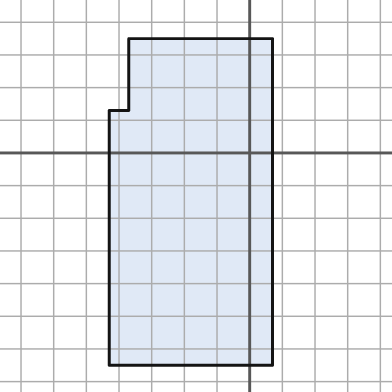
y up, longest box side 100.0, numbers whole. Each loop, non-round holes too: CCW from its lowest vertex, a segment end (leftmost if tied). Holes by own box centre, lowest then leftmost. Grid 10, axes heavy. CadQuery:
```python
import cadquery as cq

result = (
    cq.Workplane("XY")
    .moveTo(-43.0, -65.0)
    .lineTo(7.0, -65.0)
    .lineTo(7.0, 35.0)
    .lineTo(-37.0, 35.0)
    .lineTo(-37.0, 13.0)
    .lineTo(-43.0, 13.0)
    .close()
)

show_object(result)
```